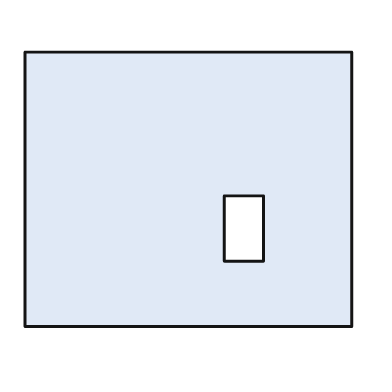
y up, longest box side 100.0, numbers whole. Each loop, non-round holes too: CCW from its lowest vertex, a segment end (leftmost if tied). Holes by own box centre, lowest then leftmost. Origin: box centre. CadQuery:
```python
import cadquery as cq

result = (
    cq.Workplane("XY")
    .moveTo(-50.0, -42.0)
    .lineTo(50.0, -42.0)
    .lineTo(50.0, 42.0)
    .lineTo(-50.0, 42.0)
    .close()
    .moveTo(11.0, -22.0)
    .lineTo(23.0, -22.0)
    .lineTo(23.0, -2.0)
    .lineTo(11.0, -2.0)
    .close()
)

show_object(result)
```